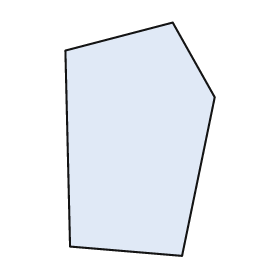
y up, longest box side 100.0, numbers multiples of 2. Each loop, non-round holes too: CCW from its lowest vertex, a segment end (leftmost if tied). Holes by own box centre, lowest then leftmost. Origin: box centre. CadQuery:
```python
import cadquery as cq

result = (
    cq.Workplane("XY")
    .moveTo(18.0, -50.0)
    .lineTo(32.0, 18.0)
    .lineTo(14.0, 50.0)
    .lineTo(-32.0, 38.0)
    .lineTo(-30.0, -46.0)
    .close()
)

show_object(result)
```